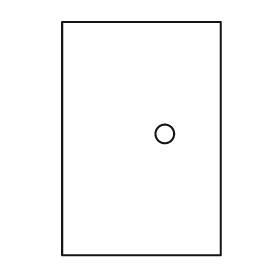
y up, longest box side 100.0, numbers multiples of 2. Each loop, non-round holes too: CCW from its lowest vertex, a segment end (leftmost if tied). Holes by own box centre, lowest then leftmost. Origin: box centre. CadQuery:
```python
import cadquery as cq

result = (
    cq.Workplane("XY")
    .moveTo(-34.0, -50.0)
    .lineTo(34.0, -50.0)
    .lineTo(34.0, 50.0)
    .lineTo(-34.0, 50.0)
    .close()
    .moveTo(10.0, 2.0)
    .circle(4.0)
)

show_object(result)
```